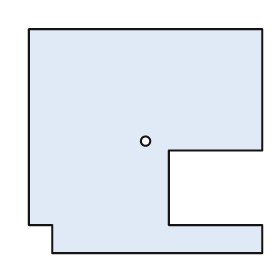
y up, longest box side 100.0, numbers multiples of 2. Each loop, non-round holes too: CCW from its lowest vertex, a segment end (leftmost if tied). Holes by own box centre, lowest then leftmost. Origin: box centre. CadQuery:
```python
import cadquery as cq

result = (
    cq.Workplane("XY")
    .moveTo(-40.0, -48.0)
    .lineTo(50.0, -48.0)
    .lineTo(50.0, -36.0)
    .lineTo(10.0, -36.0)
    .lineTo(10.0, -4.0)
    .lineTo(50.0, -4.0)
    .lineTo(50.0, 48.0)
    .lineTo(-50.0, 48.0)
    .lineTo(-50.0, -36.0)
    .lineTo(-40.0, -36.0)
    .close()
    .moveTo(0.0, 0.0)
    .circle(2.0)
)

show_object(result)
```